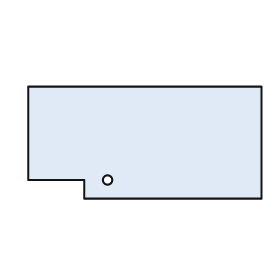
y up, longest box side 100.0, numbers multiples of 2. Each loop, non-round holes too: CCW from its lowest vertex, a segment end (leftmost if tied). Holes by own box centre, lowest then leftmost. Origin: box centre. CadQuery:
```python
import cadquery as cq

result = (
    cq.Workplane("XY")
    .moveTo(-26.0, -24.0)
    .lineTo(50.0, -24.0)
    .lineTo(50.0, 24.0)
    .lineTo(-50.0, 24.0)
    .lineTo(-50.0, -16.0)
    .lineTo(-26.0, -16.0)
    .close()
    .moveTo(-16.0, -16.0)
    .circle(2.0)
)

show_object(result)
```